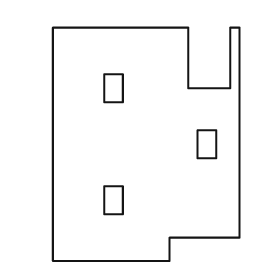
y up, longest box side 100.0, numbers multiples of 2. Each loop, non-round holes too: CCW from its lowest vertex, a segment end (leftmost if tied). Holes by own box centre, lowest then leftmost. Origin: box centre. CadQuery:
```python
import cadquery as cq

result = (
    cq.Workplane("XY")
    .moveTo(-40.0, -50.0)
    .lineTo(10.0, -50.0)
    .lineTo(10.0, -40.0)
    .lineTo(40.0, -40.0)
    .lineTo(40.0, 50.0)
    .lineTo(36.0, 50.0)
    .lineTo(36.0, 24.0)
    .lineTo(18.0, 24.0)
    .lineTo(18.0, 50.0)
    .lineTo(-40.0, 50.0)
    .close()
    .moveTo(-18.0, -30.0)
    .lineTo(-10.0, -30.0)
    .lineTo(-10.0, -18.0)
    .lineTo(-18.0, -18.0)
    .close()
    .moveTo(22.0, -6.0)
    .lineTo(30.0, -6.0)
    .lineTo(30.0, 6.0)
    .lineTo(22.0, 6.0)
    .close()
    .moveTo(-18.0, 18.0)
    .lineTo(-10.0, 18.0)
    .lineTo(-10.0, 30.0)
    .lineTo(-18.0, 30.0)
    .close()
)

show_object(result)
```